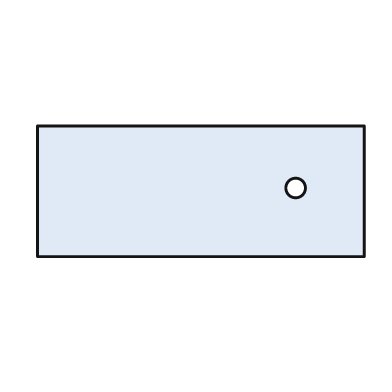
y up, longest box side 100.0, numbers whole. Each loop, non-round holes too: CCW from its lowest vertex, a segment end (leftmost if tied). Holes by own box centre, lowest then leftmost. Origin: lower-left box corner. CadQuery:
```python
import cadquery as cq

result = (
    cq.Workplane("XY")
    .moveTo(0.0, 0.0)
    .lineTo(100.0, 0.0)
    .lineTo(100.0, 40.0)
    .lineTo(0.0, 40.0)
    .close()
    .moveTo(79.0, 21.0)
    .circle(3.0)
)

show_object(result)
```